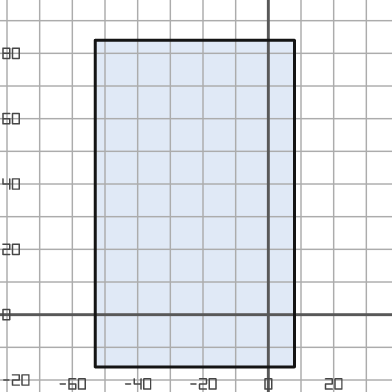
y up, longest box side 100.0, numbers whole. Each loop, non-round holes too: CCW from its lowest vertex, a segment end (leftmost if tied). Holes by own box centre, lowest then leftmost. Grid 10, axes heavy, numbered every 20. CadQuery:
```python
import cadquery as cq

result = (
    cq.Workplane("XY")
    .moveTo(-53.0, -16.0)
    .lineTo(8.0, -16.0)
    .lineTo(8.0, 84.0)
    .lineTo(-53.0, 84.0)
    .close()
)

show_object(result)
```